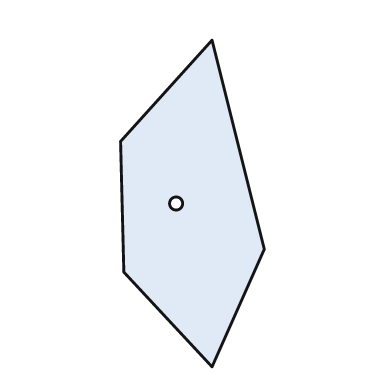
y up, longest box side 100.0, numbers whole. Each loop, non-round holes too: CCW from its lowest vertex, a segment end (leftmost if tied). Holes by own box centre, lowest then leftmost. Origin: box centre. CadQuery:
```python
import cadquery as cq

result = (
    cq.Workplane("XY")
    .moveTo(6.0, -50.0)
    .lineTo(22.0, -14.0)
    .lineTo(6.0, 50.0)
    .lineTo(-22.0, 19.0)
    .lineTo(-21.0, -21.0)
    .close()
    .moveTo(-5.0, 0.0)
    .circle(2.0)
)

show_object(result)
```